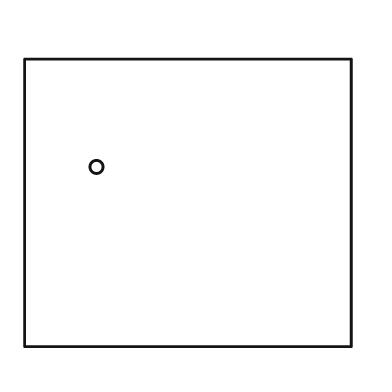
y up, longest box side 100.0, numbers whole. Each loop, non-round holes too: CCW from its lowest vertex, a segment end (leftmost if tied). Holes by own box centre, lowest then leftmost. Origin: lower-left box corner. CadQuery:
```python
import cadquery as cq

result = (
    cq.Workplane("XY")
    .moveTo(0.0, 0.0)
    .lineTo(100.0, 0.0)
    .lineTo(100.0, 88.0)
    .lineTo(0.0, 88.0)
    .close()
    .moveTo(22.0, 55.0)
    .circle(2.0)
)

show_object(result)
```